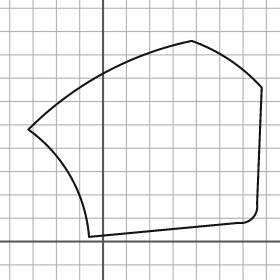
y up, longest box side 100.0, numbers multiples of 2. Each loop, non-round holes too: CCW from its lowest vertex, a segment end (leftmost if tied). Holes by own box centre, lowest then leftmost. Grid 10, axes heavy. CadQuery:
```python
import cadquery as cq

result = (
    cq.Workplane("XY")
    .moveTo(-6.0, 2.0)
    .lineTo(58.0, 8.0)
    .threePointArc((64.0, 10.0), (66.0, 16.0))
    .lineTo(68.0, 66.0)
    .threePointArc((54.0, 78.0), (38.0, 86.0))
    .threePointArc((0.0, 72.0), (-32.0, 48.0))
    .threePointArc((-14.0, 28.0), (-6.0, 2.0))
    .close()
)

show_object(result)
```